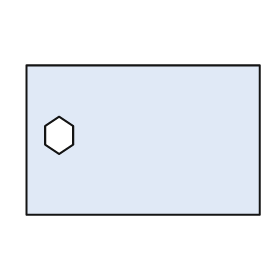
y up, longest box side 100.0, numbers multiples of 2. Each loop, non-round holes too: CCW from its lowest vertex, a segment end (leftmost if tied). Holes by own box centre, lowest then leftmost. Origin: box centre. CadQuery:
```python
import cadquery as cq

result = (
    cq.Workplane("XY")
    .moveTo(-50.0, -32.0)
    .lineTo(50.0, -32.0)
    .lineTo(50.0, 32.0)
    .lineTo(-50.0, 32.0)
    .close()
    .moveTo(-36.0, -6.0)
    .lineTo(-30.0, -2.0)
    .lineTo(-30.0, 6.0)
    .lineTo(-36.0, 10.0)
    .lineTo(-42.0, 6.0)
    .lineTo(-42.0, -2.0)
    .close()
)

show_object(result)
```